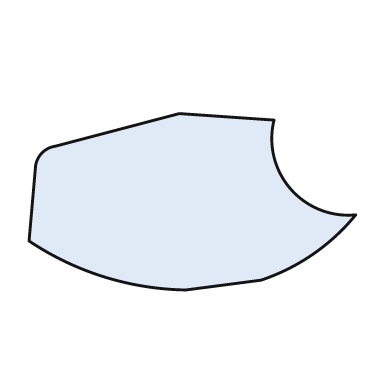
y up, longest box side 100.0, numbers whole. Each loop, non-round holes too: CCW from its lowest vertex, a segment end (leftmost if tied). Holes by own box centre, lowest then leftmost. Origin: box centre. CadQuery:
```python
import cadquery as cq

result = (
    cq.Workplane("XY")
    .moveTo(-2.0, -27.0)
    .lineTo(21.0, -24.0)
    .threePointArc((37.0, -16.0), (50.0, -4.0))
    .threePointArc((30.0, 4.0), (25.0, 25.0))
    .lineTo(-4.0, 27.0)
    .lineTo(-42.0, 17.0)
    .threePointArc((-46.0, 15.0), (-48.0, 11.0))
    .lineTo(-50.0, -12.0)
    .threePointArc((-27.0, -23.0), (-2.0, -27.0))
    .close()
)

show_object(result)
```